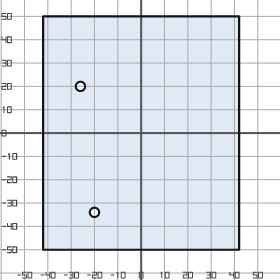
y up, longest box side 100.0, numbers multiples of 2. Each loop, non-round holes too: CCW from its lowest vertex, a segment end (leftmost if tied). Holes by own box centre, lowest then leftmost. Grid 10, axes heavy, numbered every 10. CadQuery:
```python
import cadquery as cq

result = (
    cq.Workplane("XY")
    .moveTo(-42.0, -50.0)
    .lineTo(42.0, -50.0)
    .lineTo(42.0, 50.0)
    .lineTo(-42.0, 50.0)
    .close()
    .moveTo(-20.0, -34.0)
    .circle(2.0)
    .moveTo(-26.0, 20.0)
    .circle(2.0)
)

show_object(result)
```